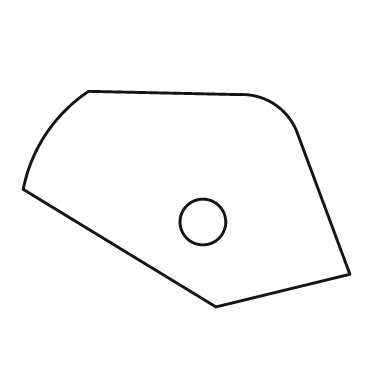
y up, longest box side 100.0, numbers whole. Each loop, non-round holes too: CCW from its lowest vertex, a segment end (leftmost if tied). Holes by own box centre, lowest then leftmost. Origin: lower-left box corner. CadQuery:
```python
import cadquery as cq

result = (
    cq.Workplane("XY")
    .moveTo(59.0, 0.0)
    .lineTo(100.0, 10.0)
    .lineTo(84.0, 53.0)
    .threePointArc((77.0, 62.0), (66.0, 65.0))
    .lineTo(20.0, 66.0)
    .threePointArc((7.0, 53.0), (0.0, 36.0))
    .close()
    .moveTo(55.0, 26.0)
    .circle(7.0)
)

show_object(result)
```